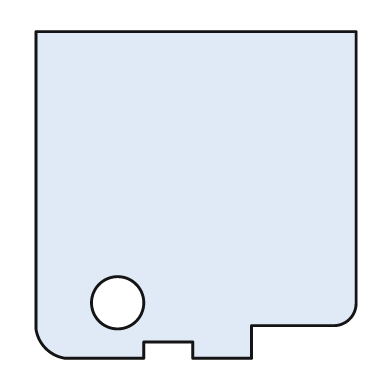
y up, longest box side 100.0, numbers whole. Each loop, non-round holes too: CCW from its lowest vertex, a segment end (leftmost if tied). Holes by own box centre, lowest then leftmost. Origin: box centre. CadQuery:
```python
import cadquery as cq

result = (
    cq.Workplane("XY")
    .moveTo(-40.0, -50.0)
    .lineTo(-16.0, -50.0)
    .lineTo(-16.0, -45.0)
    .lineTo(-1.0, -45.0)
    .lineTo(-1.0, -50.0)
    .lineTo(17.0, -50.0)
    .lineTo(17.0, -40.0)
    .lineTo(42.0, -40.0)
    .threePointArc((47.0, -38.0), (49.0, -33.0))
    .lineTo(49.0, 50.0)
    .lineTo(-49.0, 50.0)
    .lineTo(-49.0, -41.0)
    .threePointArc((-46.0, -47.0), (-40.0, -50.0))
    .close()
    .moveTo(-24.0, -33.0)
    .circle(8.0)
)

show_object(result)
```